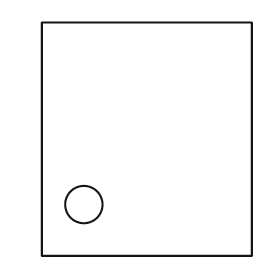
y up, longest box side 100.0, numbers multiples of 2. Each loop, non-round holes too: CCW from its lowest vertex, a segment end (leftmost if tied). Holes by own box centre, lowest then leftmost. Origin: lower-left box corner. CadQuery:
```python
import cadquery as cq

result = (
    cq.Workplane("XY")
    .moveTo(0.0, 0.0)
    .lineTo(90.0, 0.0)
    .lineTo(90.0, 100.0)
    .lineTo(0.0, 100.0)
    .close()
    .moveTo(18.0, 22.0)
    .circle(8.0)
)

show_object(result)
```